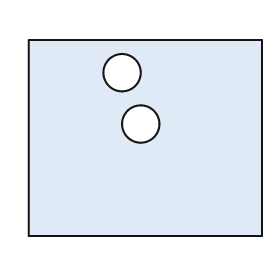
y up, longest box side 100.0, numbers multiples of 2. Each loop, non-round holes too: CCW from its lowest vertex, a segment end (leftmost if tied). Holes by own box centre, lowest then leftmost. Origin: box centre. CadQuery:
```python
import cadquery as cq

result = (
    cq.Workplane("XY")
    .moveTo(-50.0, -42.0)
    .lineTo(50.0, -42.0)
    .lineTo(50.0, 42.0)
    .lineTo(-50.0, 42.0)
    .close()
    .moveTo(-2.0, 6.0)
    .circle(8.0)
    .moveTo(-10.0, 28.0)
    .circle(8.0)
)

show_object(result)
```